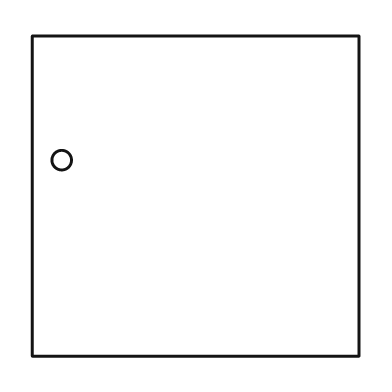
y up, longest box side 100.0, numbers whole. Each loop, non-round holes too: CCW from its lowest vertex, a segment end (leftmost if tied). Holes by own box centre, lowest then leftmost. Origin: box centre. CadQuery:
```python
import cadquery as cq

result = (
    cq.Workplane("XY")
    .moveTo(-50.0, -49.0)
    .lineTo(50.0, -49.0)
    .lineTo(50.0, 49.0)
    .lineTo(-50.0, 49.0)
    .close()
    .moveTo(-41.0, 11.0)
    .circle(3.0)
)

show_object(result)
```